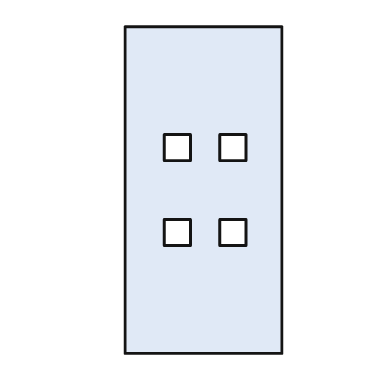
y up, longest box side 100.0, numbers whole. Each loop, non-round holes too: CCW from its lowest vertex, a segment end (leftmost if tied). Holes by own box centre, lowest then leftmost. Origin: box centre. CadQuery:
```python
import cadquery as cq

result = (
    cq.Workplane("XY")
    .moveTo(-24.0, -50.0)
    .lineTo(24.0, -50.0)
    .lineTo(24.0, 50.0)
    .lineTo(-24.0, 50.0)
    .close()
    .moveTo(-12.0, -17.0)
    .lineTo(-4.0, -17.0)
    .lineTo(-4.0, -9.0)
    .lineTo(-12.0, -9.0)
    .close()
    .moveTo(5.0, -17.0)
    .lineTo(13.0, -17.0)
    .lineTo(13.0, -9.0)
    .lineTo(5.0, -9.0)
    .close()
    .moveTo(-12.0, 9.0)
    .lineTo(-4.0, 9.0)
    .lineTo(-4.0, 17.0)
    .lineTo(-12.0, 17.0)
    .close()
    .moveTo(5.0, 9.0)
    .lineTo(13.0, 9.0)
    .lineTo(13.0, 17.0)
    .lineTo(5.0, 17.0)
    .close()
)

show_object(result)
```